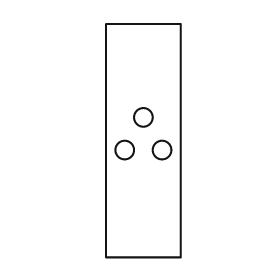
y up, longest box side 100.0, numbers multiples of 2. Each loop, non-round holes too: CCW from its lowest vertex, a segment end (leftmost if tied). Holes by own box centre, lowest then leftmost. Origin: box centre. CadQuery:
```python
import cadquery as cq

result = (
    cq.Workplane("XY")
    .moveTo(-16.0, -50.0)
    .lineTo(16.0, -50.0)
    .lineTo(16.0, 50.0)
    .lineTo(-16.0, 50.0)
    .close()
    .moveTo(-8.0, -4.0)
    .circle(4.0)
    .moveTo(8.0, -4.0)
    .circle(4.0)
    .moveTo(0.0, 10.0)
    .circle(4.0)
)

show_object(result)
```